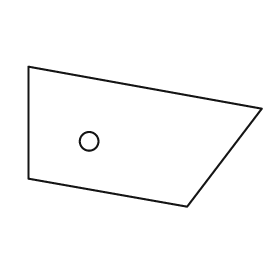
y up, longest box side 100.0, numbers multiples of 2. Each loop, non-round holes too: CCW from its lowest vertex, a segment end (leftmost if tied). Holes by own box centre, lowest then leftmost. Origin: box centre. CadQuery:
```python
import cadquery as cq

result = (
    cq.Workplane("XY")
    .moveTo(18.0, -30.0)
    .lineTo(50.0, 12.0)
    .lineTo(-50.0, 30.0)
    .lineTo(-50.0, -18.0)
    .close()
    .moveTo(-24.0, -2.0)
    .circle(4.0)
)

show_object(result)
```